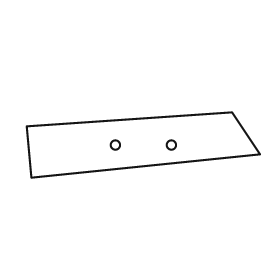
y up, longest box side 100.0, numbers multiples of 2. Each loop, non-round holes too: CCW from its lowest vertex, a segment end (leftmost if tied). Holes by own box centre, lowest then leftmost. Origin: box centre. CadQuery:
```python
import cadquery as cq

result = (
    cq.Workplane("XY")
    .moveTo(-48.0, -14.0)
    .lineTo(50.0, -4.0)
    .lineTo(38.0, 14.0)
    .lineTo(-50.0, 8.0)
    .close()
    .moveTo(-12.0, 0.0)
    .circle(2.0)
    .moveTo(12.0, 0.0)
    .circle(2.0)
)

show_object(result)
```